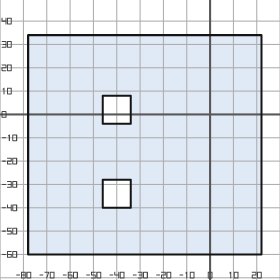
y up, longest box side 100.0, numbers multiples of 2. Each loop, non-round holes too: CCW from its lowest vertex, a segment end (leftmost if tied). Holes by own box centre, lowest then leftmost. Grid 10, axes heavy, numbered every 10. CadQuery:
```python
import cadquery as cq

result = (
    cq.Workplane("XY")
    .moveTo(-78.0, -60.0)
    .lineTo(22.0, -60.0)
    .lineTo(22.0, 34.0)
    .lineTo(-78.0, 34.0)
    .close()
    .moveTo(-46.0, -40.0)
    .lineTo(-34.0, -40.0)
    .lineTo(-34.0, -28.0)
    .lineTo(-46.0, -28.0)
    .close()
    .moveTo(-46.0, -4.0)
    .lineTo(-34.0, -4.0)
    .lineTo(-34.0, 8.0)
    .lineTo(-46.0, 8.0)
    .close()
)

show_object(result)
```